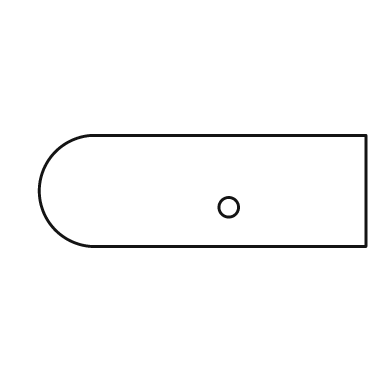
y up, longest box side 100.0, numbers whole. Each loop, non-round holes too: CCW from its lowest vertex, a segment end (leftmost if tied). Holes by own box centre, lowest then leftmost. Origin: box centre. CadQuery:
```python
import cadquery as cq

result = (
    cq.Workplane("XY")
    .moveTo(-34.0, -17.0)
    .lineTo(50.0, -17.0)
    .lineTo(50.0, 17.0)
    .lineTo(-34.0, 17.0)
    .threePointArc((-50.0, 0.0), (-34.0, -17.0))
    .close()
    .moveTo(8.0, -5.0)
    .circle(3.0)
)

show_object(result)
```